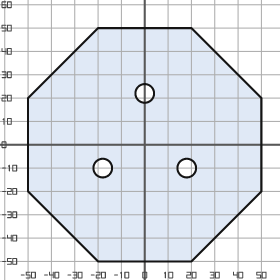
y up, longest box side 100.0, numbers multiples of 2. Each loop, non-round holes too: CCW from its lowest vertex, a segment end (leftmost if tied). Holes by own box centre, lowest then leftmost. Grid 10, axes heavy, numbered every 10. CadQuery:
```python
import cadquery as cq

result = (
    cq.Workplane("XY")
    .moveTo(-20.0, -50.0)
    .lineTo(20.0, -50.0)
    .lineTo(50.0, -20.0)
    .lineTo(50.0, 20.0)
    .lineTo(20.0, 50.0)
    .lineTo(-20.0, 50.0)
    .lineTo(-50.0, 20.0)
    .lineTo(-50.0, -20.0)
    .close()
    .moveTo(-18.0, -10.0)
    .circle(4.0)
    .moveTo(18.0, -10.0)
    .circle(4.0)
    .moveTo(0.0, 22.0)
    .circle(4.0)
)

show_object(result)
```